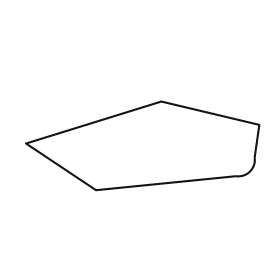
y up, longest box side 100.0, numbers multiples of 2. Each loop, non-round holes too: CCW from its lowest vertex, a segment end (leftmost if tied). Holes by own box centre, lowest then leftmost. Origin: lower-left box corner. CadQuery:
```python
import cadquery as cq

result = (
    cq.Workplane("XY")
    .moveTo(30.0, 0.0)
    .lineTo(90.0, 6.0)
    .threePointArc((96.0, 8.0), (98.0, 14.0))
    .lineTo(100.0, 28.0)
    .lineTo(58.0, 38.0)
    .lineTo(0.0, 20.0)
    .close()
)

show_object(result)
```